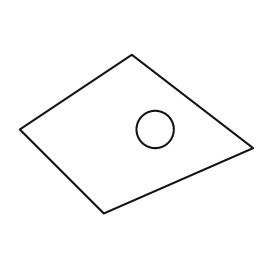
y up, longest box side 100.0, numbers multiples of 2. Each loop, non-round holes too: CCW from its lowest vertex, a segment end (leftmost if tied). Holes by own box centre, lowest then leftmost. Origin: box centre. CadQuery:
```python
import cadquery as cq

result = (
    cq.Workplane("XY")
    .moveTo(-14.0, -34.0)
    .lineTo(50.0, -6.0)
    .lineTo(-2.0, 34.0)
    .lineTo(-50.0, 2.0)
    .close()
    .moveTo(8.0, 2.0)
    .circle(8.0)
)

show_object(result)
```